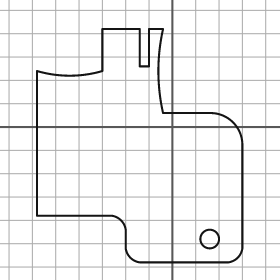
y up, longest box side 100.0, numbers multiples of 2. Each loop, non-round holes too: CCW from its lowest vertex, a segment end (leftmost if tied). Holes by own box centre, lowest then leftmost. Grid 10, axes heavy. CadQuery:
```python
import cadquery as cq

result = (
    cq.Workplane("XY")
    .moveTo(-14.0, -58.0)
    .lineTo(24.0, -58.0)
    .threePointArc((28.0, -56.0), (30.0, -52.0))
    .lineTo(30.0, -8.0)
    .threePointArc((26.0, 2.0), (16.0, 6.0))
    .lineTo(-4.0, 6.0)
    .threePointArc((-6.0, 24.0), (-4.0, 42.0))
    .lineTo(-10.0, 42.0)
    .lineTo(-10.0, 26.0)
    .lineTo(-14.0, 26.0)
    .lineTo(-14.0, 42.0)
    .lineTo(-30.0, 42.0)
    .lineTo(-30.0, 24.0)
    .threePointArc((-44.0, 22.0), (-58.0, 24.0))
    .lineTo(-58.0, -38.0)
    .lineTo(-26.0, -38.0)
    .threePointArc((-22.0, -40.0), (-20.0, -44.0))
    .lineTo(-20.0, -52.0)
    .threePointArc((-18.0, -56.0), (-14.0, -58.0))
    .close()
    .moveTo(16.0, -48.0)
    .circle(4.0)
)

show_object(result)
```